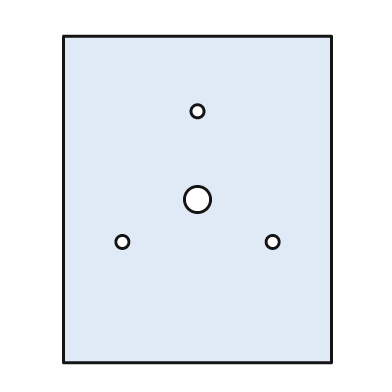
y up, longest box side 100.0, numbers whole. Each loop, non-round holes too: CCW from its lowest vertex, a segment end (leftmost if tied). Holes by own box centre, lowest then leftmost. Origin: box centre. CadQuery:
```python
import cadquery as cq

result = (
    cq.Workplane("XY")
    .moveTo(-41.0, -50.0)
    .lineTo(41.0, -50.0)
    .lineTo(41.0, 50.0)
    .lineTo(-41.0, 50.0)
    .close()
    .moveTo(-23.0, -13.0)
    .circle(2.0)
    .moveTo(23.0, -13.0)
    .circle(2.0)
    .moveTo(0.0, 0.0)
    .circle(4.0)
    .moveTo(0.0, 27.0)
    .circle(2.0)
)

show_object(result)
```